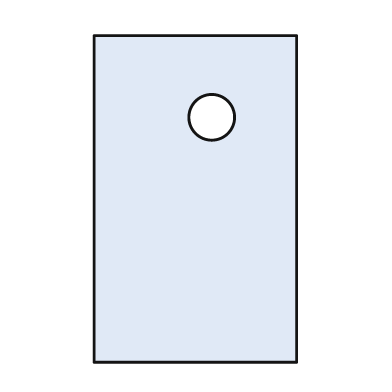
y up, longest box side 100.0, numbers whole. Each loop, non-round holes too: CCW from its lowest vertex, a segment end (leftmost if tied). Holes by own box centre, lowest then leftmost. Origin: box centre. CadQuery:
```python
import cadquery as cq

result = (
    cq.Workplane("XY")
    .moveTo(-31.0, -50.0)
    .lineTo(31.0, -50.0)
    .lineTo(31.0, 50.0)
    .lineTo(-31.0, 50.0)
    .close()
    .moveTo(5.0, 25.0)
    .circle(7.0)
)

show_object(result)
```